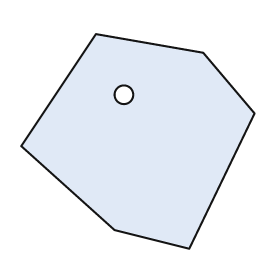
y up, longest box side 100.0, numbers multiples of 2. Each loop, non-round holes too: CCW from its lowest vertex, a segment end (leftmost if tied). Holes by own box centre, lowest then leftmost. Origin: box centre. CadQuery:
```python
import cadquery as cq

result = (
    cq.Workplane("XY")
    .moveTo(22.0, -46.0)
    .lineTo(50.0, 12.0)
    .lineTo(28.0, 38.0)
    .lineTo(-18.0, 46.0)
    .lineTo(-50.0, -2.0)
    .lineTo(-10.0, -38.0)
    .close()
    .moveTo(-6.0, 20.0)
    .circle(4.0)
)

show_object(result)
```